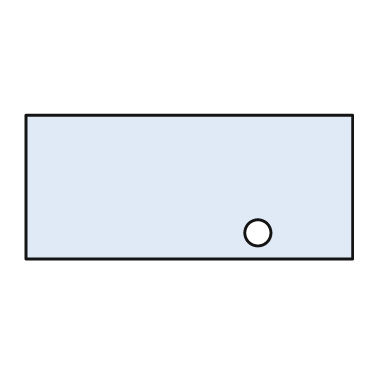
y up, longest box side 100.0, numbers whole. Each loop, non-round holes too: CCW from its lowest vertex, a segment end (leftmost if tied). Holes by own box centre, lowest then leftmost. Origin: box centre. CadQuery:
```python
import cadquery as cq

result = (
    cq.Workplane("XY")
    .moveTo(-50.0, -22.0)
    .lineTo(50.0, -22.0)
    .lineTo(50.0, 22.0)
    .lineTo(-50.0, 22.0)
    .close()
    .moveTo(21.0, -14.0)
    .circle(4.0)
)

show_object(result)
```